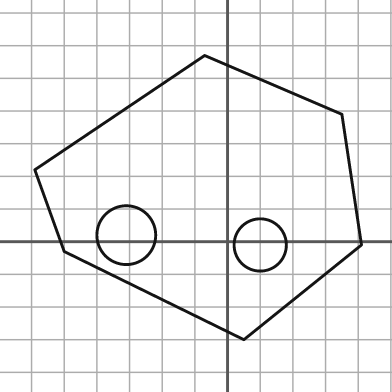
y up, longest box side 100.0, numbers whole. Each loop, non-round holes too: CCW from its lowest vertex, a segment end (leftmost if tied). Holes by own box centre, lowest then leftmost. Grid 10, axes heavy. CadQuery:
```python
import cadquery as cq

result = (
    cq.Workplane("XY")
    .moveTo(5.0, -30.0)
    .lineTo(41.0, -1.0)
    .lineTo(35.0, 39.0)
    .lineTo(-7.0, 57.0)
    .lineTo(-59.0, 22.0)
    .lineTo(-50.0, -3.0)
    .close()
    .moveTo(10.0, -1.0)
    .circle(8.0)
    .moveTo(-31.0, 2.0)
    .circle(9.0)
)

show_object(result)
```